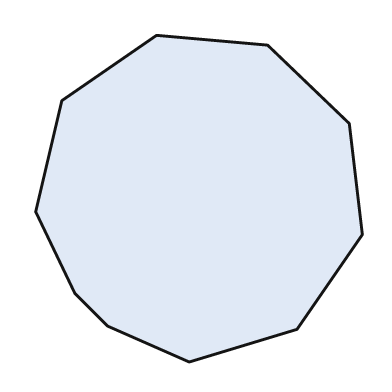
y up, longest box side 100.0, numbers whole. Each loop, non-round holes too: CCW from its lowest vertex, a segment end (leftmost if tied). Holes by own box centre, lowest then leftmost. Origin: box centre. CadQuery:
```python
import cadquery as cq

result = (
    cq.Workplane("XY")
    .moveTo(-3.0, -50.0)
    .lineTo(30.0, -40.0)
    .lineTo(50.0, -11.0)
    .lineTo(46.0, 23.0)
    .lineTo(21.0, 47.0)
    .lineTo(-13.0, 50.0)
    .lineTo(-42.0, 30.0)
    .lineTo(-50.0, -4.0)
    .lineTo(-38.0, -29.0)
    .lineTo(-28.0, -39.0)
    .close()
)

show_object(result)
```